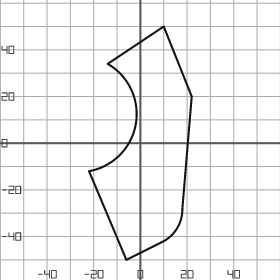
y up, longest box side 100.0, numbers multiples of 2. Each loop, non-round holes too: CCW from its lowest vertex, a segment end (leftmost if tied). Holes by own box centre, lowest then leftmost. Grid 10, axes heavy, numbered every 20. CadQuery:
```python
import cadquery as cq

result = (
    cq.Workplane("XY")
    .moveTo(-6.0, -50.0)
    .lineTo(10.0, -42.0)
    .threePointArc((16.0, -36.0), (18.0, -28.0))
    .lineTo(22.0, 20.0)
    .lineTo(10.0, 50.0)
    .lineTo(-14.0, 34.0)
    .threePointArc((-2.0, 8.0), (-22.0, -12.0))
    .close()
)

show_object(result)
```